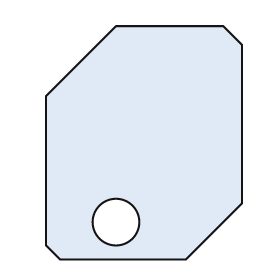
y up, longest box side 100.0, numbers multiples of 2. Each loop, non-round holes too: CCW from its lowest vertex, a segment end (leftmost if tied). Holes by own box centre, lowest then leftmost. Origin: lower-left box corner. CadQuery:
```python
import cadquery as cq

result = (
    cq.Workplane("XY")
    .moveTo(6.0, 0.0)
    .lineTo(60.0, 0.0)
    .lineTo(84.0, 24.0)
    .lineTo(84.0, 92.0)
    .lineTo(76.0, 100.0)
    .lineTo(30.0, 100.0)
    .lineTo(0.0, 70.0)
    .lineTo(0.0, 6.0)
    .close()
    .moveTo(30.0, 16.0)
    .circle(10.0)
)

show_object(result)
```